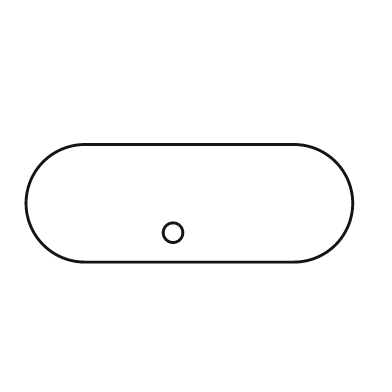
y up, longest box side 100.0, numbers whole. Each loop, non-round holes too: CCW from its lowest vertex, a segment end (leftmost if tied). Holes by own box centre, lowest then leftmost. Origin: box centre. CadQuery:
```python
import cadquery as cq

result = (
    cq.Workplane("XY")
    .moveTo(-32.0, -18.0)
    .lineTo(32.0, -18.0)
    .threePointArc((50.0, 0.0), (32.0, 18.0))
    .lineTo(-32.0, 18.0)
    .threePointArc((-50.0, 0.0), (-32.0, -18.0))
    .close()
    .moveTo(-5.0, -9.0)
    .circle(3.0)
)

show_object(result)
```